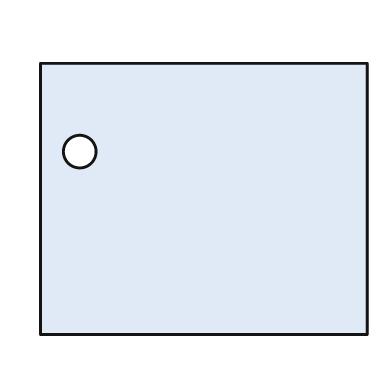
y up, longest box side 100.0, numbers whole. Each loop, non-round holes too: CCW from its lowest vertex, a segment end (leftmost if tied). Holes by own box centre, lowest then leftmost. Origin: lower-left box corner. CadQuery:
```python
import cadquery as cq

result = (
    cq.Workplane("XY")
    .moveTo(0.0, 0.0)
    .lineTo(100.0, 0.0)
    .lineTo(100.0, 83.0)
    .lineTo(0.0, 83.0)
    .close()
    .moveTo(12.0, 56.0)
    .circle(5.0)
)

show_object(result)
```